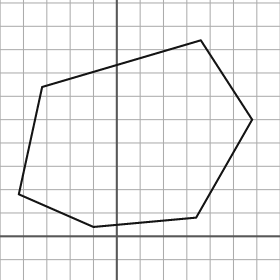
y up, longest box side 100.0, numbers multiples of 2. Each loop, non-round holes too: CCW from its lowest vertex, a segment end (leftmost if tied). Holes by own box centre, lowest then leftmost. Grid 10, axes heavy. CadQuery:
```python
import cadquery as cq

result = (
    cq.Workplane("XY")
    .moveTo(-10.0, 4.0)
    .lineTo(34.0, 8.0)
    .lineTo(58.0, 50.0)
    .lineTo(36.0, 84.0)
    .lineTo(-32.0, 64.0)
    .lineTo(-42.0, 18.0)
    .close()
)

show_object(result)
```